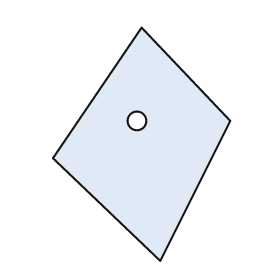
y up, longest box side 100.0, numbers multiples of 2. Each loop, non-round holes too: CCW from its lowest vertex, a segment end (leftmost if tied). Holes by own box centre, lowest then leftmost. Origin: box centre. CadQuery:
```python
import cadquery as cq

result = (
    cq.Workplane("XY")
    .moveTo(8.0, -50.0)
    .lineTo(38.0, 10.0)
    .lineTo(0.0, 50.0)
    .lineTo(-38.0, -6.0)
    .close()
    .moveTo(-2.0, 10.0)
    .circle(4.0)
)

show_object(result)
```